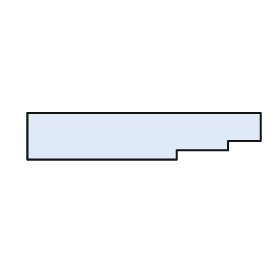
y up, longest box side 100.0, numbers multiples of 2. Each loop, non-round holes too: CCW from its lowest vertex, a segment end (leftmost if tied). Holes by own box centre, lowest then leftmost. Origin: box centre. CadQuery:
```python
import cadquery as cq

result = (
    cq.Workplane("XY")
    .moveTo(-50.0, -10.0)
    .lineTo(14.0, -10.0)
    .lineTo(14.0, -6.0)
    .lineTo(36.0, -6.0)
    .lineTo(36.0, -2.0)
    .lineTo(50.0, -2.0)
    .lineTo(50.0, 10.0)
    .lineTo(-50.0, 10.0)
    .close()
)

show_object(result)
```